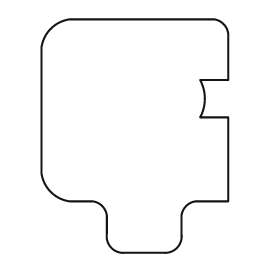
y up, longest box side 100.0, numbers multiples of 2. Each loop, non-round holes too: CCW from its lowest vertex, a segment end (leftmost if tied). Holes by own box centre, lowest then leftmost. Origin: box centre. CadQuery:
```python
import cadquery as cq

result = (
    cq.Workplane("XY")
    .moveTo(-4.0, -50.0)
    .lineTo(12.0, -50.0)
    .threePointArc((18.0, -48.0), (20.0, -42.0))
    .lineTo(20.0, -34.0)
    .threePointArc((22.0, -30.0), (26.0, -28.0))
    .lineTo(40.0, -28.0)
    .lineTo(40.0, 8.0)
    .lineTo(28.0, 8.0)
    .threePointArc((30.0, 16.0), (28.0, 24.0))
    .lineTo(40.0, 24.0)
    .lineTo(40.0, 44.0)
    .threePointArc((38.0, 48.0), (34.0, 50.0))
    .lineTo(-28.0, 50.0)
    .threePointArc((-36.0, 46.0), (-40.0, 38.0))
    .lineTo(-40.0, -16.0)
    .threePointArc((-36.0, -24.0), (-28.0, -28.0))
    .lineTo(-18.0, -28.0)
    .threePointArc((-14.0, -30.0), (-12.0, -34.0))
    .lineTo(-12.0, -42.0)
    .threePointArc((-10.0, -48.0), (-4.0, -50.0))
    .close()
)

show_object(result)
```